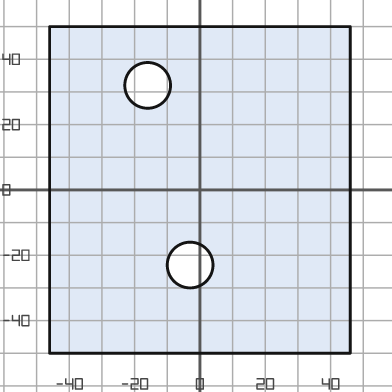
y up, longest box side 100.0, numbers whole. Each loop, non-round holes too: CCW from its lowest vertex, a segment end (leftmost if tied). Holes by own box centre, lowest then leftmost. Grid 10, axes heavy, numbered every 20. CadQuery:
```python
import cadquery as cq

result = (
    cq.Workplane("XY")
    .moveTo(-46.0, -50.0)
    .lineTo(46.0, -50.0)
    .lineTo(46.0, 50.0)
    .lineTo(-46.0, 50.0)
    .close()
    .moveTo(-3.0, -23.0)
    .circle(7.0)
    .moveTo(-16.0, 32.0)
    .circle(7.0)
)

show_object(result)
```